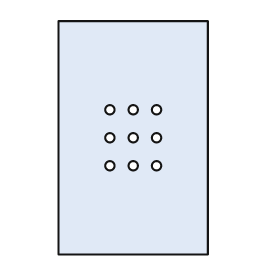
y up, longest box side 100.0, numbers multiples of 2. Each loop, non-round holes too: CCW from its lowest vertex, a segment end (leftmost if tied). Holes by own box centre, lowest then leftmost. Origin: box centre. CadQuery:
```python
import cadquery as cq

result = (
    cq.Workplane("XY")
    .moveTo(-32.0, -50.0)
    .lineTo(32.0, -50.0)
    .lineTo(32.0, 50.0)
    .lineTo(-32.0, 50.0)
    .close()
    .moveTo(-10.0, -12.0)
    .circle(2.0)
    .moveTo(0.0, -12.0)
    .circle(2.0)
    .moveTo(10.0, -12.0)
    .circle(2.0)
    .moveTo(-10.0, 0.0)
    .circle(2.0)
    .moveTo(0.0, 0.0)
    .circle(2.0)
    .moveTo(10.0, 0.0)
    .circle(2.0)
    .moveTo(-10.0, 12.0)
    .circle(2.0)
    .moveTo(0.0, 12.0)
    .circle(2.0)
    .moveTo(10.0, 12.0)
    .circle(2.0)
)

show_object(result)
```